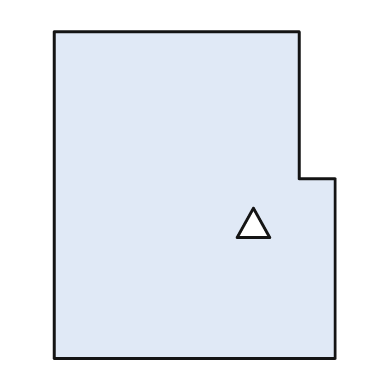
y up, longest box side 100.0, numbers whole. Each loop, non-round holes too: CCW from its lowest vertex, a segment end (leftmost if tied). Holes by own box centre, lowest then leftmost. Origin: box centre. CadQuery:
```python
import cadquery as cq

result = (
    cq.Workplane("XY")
    .moveTo(-43.0, -50.0)
    .lineTo(43.0, -50.0)
    .lineTo(43.0, 5.0)
    .lineTo(32.0, 5.0)
    .lineTo(32.0, 50.0)
    .lineTo(-43.0, 50.0)
    .close()
    .moveTo(13.0, -13.0)
    .lineTo(23.0, -13.0)
    .lineTo(18.0, -4.0)
    .close()
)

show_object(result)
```